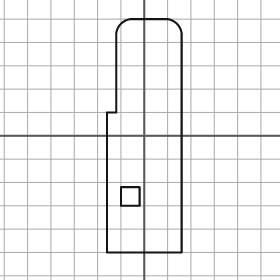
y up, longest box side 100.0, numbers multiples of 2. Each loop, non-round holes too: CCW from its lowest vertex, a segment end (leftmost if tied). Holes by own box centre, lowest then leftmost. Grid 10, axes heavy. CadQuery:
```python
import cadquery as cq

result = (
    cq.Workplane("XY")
    .moveTo(-16.0, -50.0)
    .lineTo(16.0, -50.0)
    .lineTo(16.0, 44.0)
    .threePointArc((14.0, 48.0), (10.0, 50.0))
    .lineTo(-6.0, 50.0)
    .threePointArc((-10.0, 48.0), (-12.0, 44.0))
    .lineTo(-12.0, 10.0)
    .lineTo(-16.0, 10.0)
    .close()
    .moveTo(-10.0, -30.0)
    .lineTo(-2.0, -30.0)
    .lineTo(-2.0, -22.0)
    .lineTo(-10.0, -22.0)
    .close()
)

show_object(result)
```